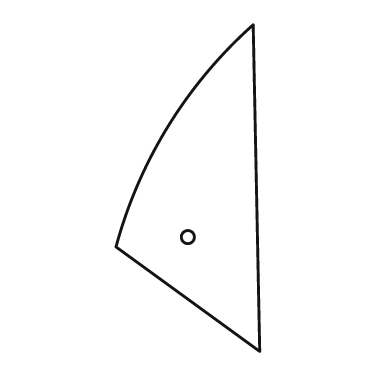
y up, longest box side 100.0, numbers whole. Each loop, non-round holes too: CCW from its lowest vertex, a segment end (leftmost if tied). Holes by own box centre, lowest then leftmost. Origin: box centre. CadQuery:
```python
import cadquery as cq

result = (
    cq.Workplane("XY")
    .moveTo(22.0, -50.0)
    .lineTo(20.0, 50.0)
    .threePointArc((-6.0, 19.0), (-22.0, -18.0))
    .close()
    .moveTo(0.0, -15.0)
    .circle(2.0)
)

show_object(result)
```